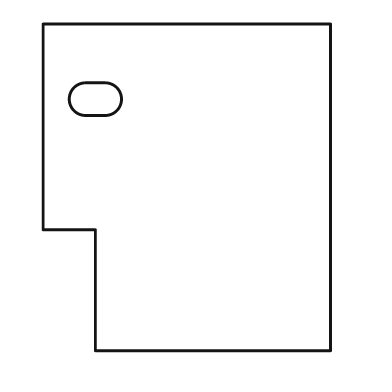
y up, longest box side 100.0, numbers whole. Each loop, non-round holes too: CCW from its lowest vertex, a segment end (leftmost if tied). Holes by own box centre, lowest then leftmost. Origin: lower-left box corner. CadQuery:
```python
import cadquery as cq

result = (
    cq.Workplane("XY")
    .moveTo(16.0, 0.0)
    .lineTo(88.0, 0.0)
    .lineTo(88.0, 100.0)
    .lineTo(0.0, 100.0)
    .lineTo(0.0, 37.0)
    .lineTo(16.0, 37.0)
    .close()
    .moveTo(13.0, 72.0)
    .lineTo(19.0, 72.0)
    .threePointArc((24.0, 77.0), (19.0, 82.0))
    .lineTo(13.0, 82.0)
    .threePointArc((8.0, 77.0), (13.0, 72.0))
    .close()
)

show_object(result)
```